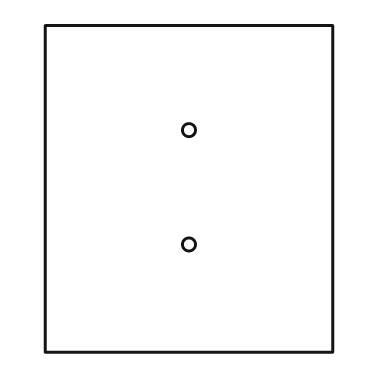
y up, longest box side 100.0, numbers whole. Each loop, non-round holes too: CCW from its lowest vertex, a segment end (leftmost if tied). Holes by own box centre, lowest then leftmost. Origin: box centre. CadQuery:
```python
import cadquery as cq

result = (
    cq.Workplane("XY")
    .moveTo(-44.0, -50.0)
    .lineTo(44.0, -50.0)
    .lineTo(44.0, 50.0)
    .lineTo(-44.0, 50.0)
    .close()
    .moveTo(0.0, -17.0)
    .circle(2.0)
    .moveTo(0.0, 18.0)
    .circle(2.0)
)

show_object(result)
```